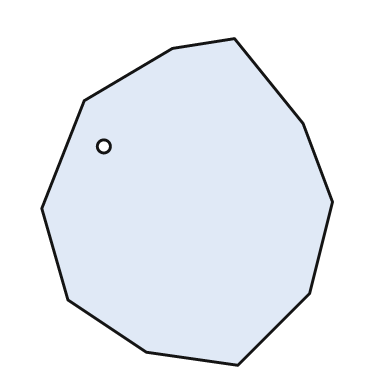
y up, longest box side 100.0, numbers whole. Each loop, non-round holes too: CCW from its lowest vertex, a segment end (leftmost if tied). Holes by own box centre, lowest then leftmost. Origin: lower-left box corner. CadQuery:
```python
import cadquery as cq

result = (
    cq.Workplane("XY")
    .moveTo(60.0, 0.0)
    .lineTo(82.0, 22.0)
    .lineTo(89.0, 50.0)
    .lineTo(80.0, 74.0)
    .lineTo(59.0, 100.0)
    .lineTo(40.0, 97.0)
    .lineTo(13.0, 81.0)
    .lineTo(0.0, 48.0)
    .lineTo(8.0, 20.0)
    .lineTo(32.0, 4.0)
    .close()
    .moveTo(19.0, 67.0)
    .circle(2.0)
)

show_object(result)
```